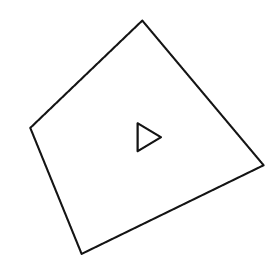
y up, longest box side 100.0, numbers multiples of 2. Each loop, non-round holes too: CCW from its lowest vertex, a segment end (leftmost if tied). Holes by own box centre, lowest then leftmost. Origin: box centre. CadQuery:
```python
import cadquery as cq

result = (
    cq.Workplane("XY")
    .moveTo(-28.0, -50.0)
    .lineTo(50.0, -12.0)
    .lineTo(-2.0, 50.0)
    .lineTo(-50.0, 4.0)
    .close()
    .moveTo(-4.0, -6.0)
    .lineTo(6.0, 0.0)
    .lineTo(-4.0, 6.0)
    .close()
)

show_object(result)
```